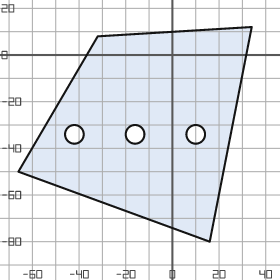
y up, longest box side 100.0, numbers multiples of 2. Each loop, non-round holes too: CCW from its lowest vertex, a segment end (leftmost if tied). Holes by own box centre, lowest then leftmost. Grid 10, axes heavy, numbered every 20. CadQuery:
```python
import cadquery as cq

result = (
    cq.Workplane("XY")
    .moveTo(16.0, -80.0)
    .lineTo(34.0, 12.0)
    .lineTo(-32.0, 8.0)
    .lineTo(-66.0, -50.0)
    .close()
    .moveTo(-42.0, -34.0)
    .circle(4.0)
    .moveTo(-16.0, -34.0)
    .circle(4.0)
    .moveTo(10.0, -34.0)
    .circle(4.0)
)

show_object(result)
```